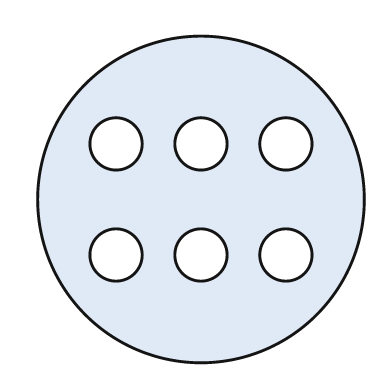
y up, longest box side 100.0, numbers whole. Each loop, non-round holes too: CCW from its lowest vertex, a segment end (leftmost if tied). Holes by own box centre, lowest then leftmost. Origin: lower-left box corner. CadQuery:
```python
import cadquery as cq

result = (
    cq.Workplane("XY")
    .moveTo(50.0, 50.0)
    .circle(50.0)
    .moveTo(24.0, 33.0)
    .circle(8.0)
    .moveTo(50.0, 33.0)
    .circle(8.0)
    .moveTo(76.0, 33.0)
    .circle(8.0)
    .moveTo(24.0, 67.0)
    .circle(8.0)
    .moveTo(50.0, 67.0)
    .circle(8.0)
    .moveTo(76.0, 67.0)
    .circle(8.0)
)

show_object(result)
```